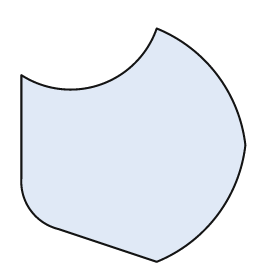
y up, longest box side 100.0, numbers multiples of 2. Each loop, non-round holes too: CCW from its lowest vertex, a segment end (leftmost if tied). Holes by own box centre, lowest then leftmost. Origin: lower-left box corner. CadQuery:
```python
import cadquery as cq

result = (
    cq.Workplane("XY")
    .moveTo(58.0, 0.0)
    .threePointArc((84.0, 20.0), (96.0, 50.0))
    .threePointArc((84.0, 80.0), (58.0, 100.0))
    .threePointArc((34.0, 76.0), (0.0, 80.0))
    .lineTo(0.0, 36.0)
    .threePointArc((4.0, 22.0), (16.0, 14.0))
    .close()
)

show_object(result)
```